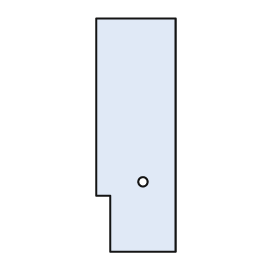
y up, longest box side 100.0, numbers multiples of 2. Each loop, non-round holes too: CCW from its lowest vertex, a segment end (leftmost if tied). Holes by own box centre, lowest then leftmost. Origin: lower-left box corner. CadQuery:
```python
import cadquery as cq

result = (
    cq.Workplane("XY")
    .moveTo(6.0, 0.0)
    .lineTo(34.0, 0.0)
    .lineTo(34.0, 100.0)
    .lineTo(0.0, 100.0)
    .lineTo(0.0, 24.0)
    .lineTo(6.0, 24.0)
    .close()
    .moveTo(20.0, 30.0)
    .circle(2.0)
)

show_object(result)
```